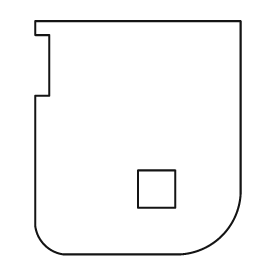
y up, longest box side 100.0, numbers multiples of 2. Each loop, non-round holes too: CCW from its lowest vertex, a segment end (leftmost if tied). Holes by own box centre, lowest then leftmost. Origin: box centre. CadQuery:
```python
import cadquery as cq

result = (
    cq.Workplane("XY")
    .moveTo(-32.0, -50.0)
    .lineTo(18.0, -50.0)
    .threePointArc((36.0, -42.0), (44.0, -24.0))
    .lineTo(44.0, 50.0)
    .lineTo(-44.0, 50.0)
    .lineTo(-44.0, 44.0)
    .lineTo(-38.0, 44.0)
    .lineTo(-38.0, 18.0)
    .lineTo(-44.0, 18.0)
    .lineTo(-44.0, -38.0)
    .threePointArc((-40.0, -46.0), (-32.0, -50.0))
    .close()
    .moveTo(0.0, -30.0)
    .lineTo(16.0, -30.0)
    .lineTo(16.0, -14.0)
    .lineTo(0.0, -14.0)
    .close()
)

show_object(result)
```